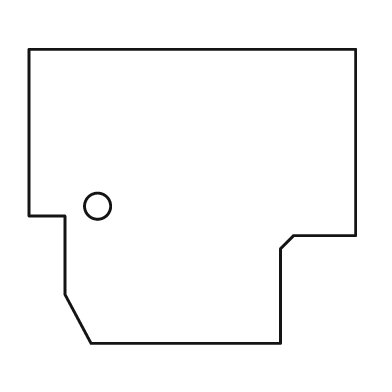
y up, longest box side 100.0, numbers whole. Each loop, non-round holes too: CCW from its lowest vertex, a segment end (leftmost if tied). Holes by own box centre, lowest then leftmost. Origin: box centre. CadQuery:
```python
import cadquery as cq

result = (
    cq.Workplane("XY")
    .moveTo(-31.0, -45.0)
    .lineTo(27.0, -45.0)
    .lineTo(27.0, -16.0)
    .lineTo(31.0, -12.0)
    .lineTo(50.0, -12.0)
    .lineTo(50.0, 45.0)
    .lineTo(-50.0, 45.0)
    .lineTo(-50.0, -6.0)
    .lineTo(-39.0, -6.0)
    .lineTo(-39.0, -30.0)
    .close()
    .moveTo(-29.0, -3.0)
    .circle(4.0)
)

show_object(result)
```